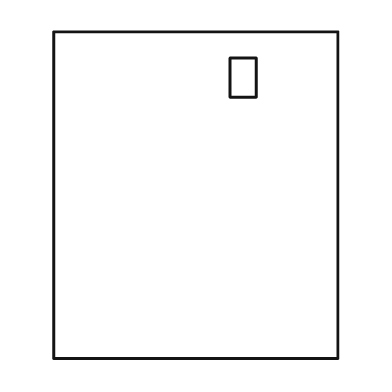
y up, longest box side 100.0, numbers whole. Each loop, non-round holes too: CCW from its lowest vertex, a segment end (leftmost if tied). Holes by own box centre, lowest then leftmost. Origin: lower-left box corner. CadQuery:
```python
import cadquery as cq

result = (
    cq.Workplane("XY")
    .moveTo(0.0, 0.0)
    .lineTo(87.0, 0.0)
    .lineTo(87.0, 100.0)
    .lineTo(0.0, 100.0)
    .close()
    .moveTo(54.0, 80.0)
    .lineTo(62.0, 80.0)
    .lineTo(62.0, 92.0)
    .lineTo(54.0, 92.0)
    .close()
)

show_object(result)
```